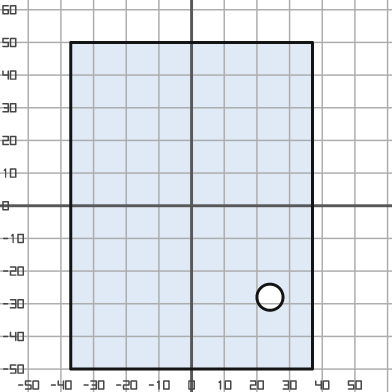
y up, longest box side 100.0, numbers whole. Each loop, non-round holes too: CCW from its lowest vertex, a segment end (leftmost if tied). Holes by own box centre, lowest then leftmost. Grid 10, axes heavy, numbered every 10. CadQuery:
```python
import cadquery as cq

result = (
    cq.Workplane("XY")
    .moveTo(-37.0, -50.0)
    .lineTo(37.0, -50.0)
    .lineTo(37.0, 50.0)
    .lineTo(-37.0, 50.0)
    .close()
    .moveTo(24.0, -28.0)
    .circle(4.0)
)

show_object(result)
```